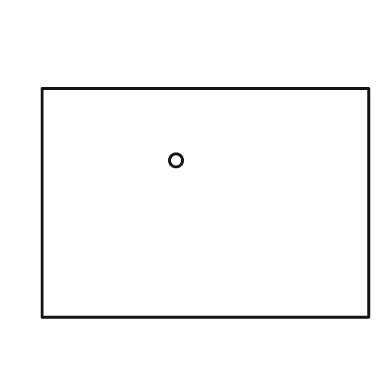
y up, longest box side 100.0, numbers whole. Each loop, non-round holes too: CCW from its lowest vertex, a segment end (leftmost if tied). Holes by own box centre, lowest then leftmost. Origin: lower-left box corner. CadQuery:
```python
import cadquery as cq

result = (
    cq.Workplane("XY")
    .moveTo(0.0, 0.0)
    .lineTo(100.0, 0.0)
    .lineTo(100.0, 70.0)
    .lineTo(0.0, 70.0)
    .close()
    .moveTo(41.0, 48.0)
    .circle(2.0)
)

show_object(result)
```